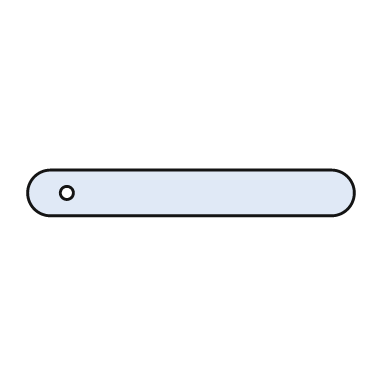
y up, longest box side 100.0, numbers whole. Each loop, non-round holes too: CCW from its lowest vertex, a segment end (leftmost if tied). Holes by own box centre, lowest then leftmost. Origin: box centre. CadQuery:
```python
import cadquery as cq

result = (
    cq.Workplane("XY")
    .moveTo(-43.0, -7.0)
    .lineTo(43.0, -7.0)
    .threePointArc((50.0, 0.0), (43.0, 7.0))
    .lineTo(-43.0, 7.0)
    .threePointArc((-50.0, 0.0), (-43.0, -7.0))
    .close()
    .moveTo(-38.0, 0.0)
    .circle(2.0)
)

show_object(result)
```